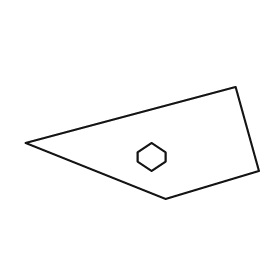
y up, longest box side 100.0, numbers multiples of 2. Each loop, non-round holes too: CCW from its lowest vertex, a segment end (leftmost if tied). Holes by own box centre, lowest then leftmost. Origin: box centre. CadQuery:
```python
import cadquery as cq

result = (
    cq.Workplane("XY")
    .moveTo(10.0, -24.0)
    .lineTo(50.0, -12.0)
    .lineTo(40.0, 24.0)
    .lineTo(-50.0, 0.0)
    .close()
    .moveTo(4.0, -12.0)
    .lineTo(10.0, -8.0)
    .lineTo(10.0, -4.0)
    .lineTo(4.0, 0.0)
    .lineTo(-2.0, -4.0)
    .lineTo(-2.0, -8.0)
    .close()
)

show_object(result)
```